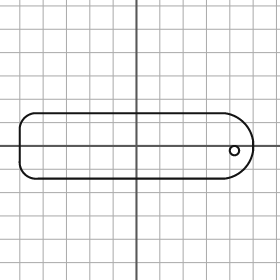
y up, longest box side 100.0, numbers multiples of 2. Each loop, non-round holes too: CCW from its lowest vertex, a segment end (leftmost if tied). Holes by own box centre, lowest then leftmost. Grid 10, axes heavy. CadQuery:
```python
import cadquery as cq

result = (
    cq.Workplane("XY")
    .moveTo(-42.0, -14.0)
    .lineTo(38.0, -14.0)
    .threePointArc((46.0, -10.0), (50.0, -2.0))
    .lineTo(50.0, 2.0)
    .threePointArc((46.0, 10.0), (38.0, 14.0))
    .lineTo(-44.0, 14.0)
    .threePointArc((-48.0, 12.0), (-50.0, 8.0))
    .lineTo(-50.0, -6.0)
    .threePointArc((-48.0, -12.0), (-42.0, -14.0))
    .close()
    .moveTo(42.0, -2.0)
    .circle(2.0)
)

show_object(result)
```